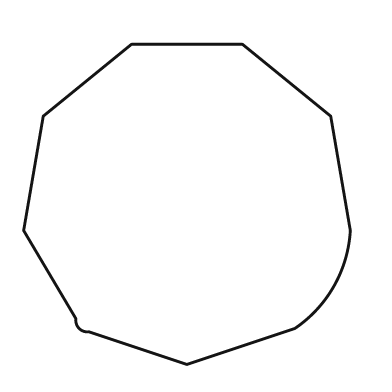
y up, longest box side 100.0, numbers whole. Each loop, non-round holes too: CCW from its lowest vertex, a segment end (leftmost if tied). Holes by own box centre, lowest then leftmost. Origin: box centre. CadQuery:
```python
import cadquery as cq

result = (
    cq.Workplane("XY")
    .moveTo(0.0, -49.0)
    .lineTo(33.0, -38.0)
    .threePointArc((45.0, -25.0), (50.0, -8.0))
    .lineTo(44.0, 27.0)
    .lineTo(17.0, 49.0)
    .lineTo(-17.0, 49.0)
    .lineTo(-44.0, 27.0)
    .lineTo(-50.0, -8.0)
    .lineTo(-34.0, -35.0)
    .threePointArc((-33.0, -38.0), (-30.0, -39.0))
    .close()
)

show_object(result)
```